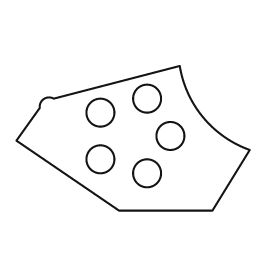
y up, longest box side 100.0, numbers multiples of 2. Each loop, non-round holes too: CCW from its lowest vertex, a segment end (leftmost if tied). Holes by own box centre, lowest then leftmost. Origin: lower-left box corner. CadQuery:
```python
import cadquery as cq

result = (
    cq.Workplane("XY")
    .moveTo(44.0, 0.0)
    .lineTo(84.0, 0.0)
    .lineTo(100.0, 26.0)
    .threePointArc((80.0, 40.0), (70.0, 62.0))
    .lineTo(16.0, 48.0)
    .threePointArc((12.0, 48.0), (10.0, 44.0))
    .lineTo(0.0, 30.0)
    .close()
    .moveTo(56.0, 16.0)
    .circle(6.0)
    .moveTo(36.0, 22.0)
    .circle(6.0)
    .moveTo(66.0, 32.0)
    .circle(6.0)
    .moveTo(36.0, 42.0)
    .circle(6.0)
    .moveTo(56.0, 48.0)
    .circle(6.0)
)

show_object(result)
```